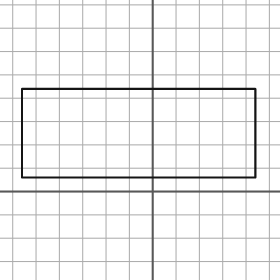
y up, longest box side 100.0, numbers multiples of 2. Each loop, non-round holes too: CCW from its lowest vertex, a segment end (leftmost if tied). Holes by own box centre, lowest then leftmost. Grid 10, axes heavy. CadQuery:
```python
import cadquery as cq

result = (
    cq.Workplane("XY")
    .moveTo(-56.0, 6.0)
    .lineTo(44.0, 6.0)
    .lineTo(44.0, 44.0)
    .lineTo(-56.0, 44.0)
    .close()
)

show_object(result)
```